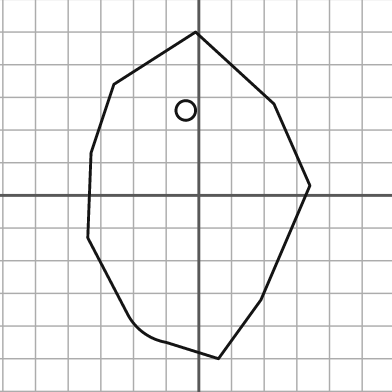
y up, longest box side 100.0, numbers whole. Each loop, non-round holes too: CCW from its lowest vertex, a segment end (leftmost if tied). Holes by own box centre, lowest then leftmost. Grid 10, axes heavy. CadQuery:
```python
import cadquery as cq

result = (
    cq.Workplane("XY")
    .moveTo(6.0, -50.0)
    .lineTo(19.0, -32.0)
    .lineTo(34.0, 3.0)
    .lineTo(23.0, 28.0)
    .lineTo(-1.0, 50.0)
    .lineTo(-26.0, 34.0)
    .lineTo(-33.0, 13.0)
    .lineTo(-34.0, -13.0)
    .lineTo(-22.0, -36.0)
    .threePointArc((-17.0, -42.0), (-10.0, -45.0))
    .close()
    .moveTo(-4.0, 26.0)
    .circle(3.0)
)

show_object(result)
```